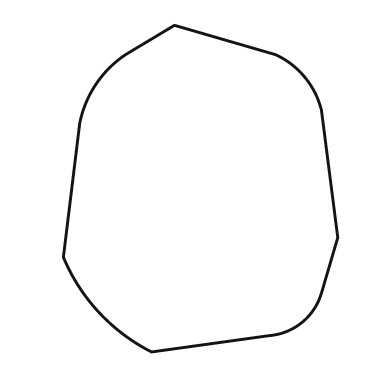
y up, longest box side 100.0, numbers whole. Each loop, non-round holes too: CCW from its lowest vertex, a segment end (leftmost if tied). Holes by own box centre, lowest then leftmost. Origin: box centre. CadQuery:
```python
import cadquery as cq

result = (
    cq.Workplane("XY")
    .moveTo(-15.0, -50.0)
    .lineTo(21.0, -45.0)
    .threePointArc((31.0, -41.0), (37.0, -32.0))
    .lineTo(42.0, -15.0)
    .lineTo(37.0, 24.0)
    .threePointArc((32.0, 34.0), (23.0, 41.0))
    .lineTo(-8.0, 50.0)
    .lineTo(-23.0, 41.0)
    .threePointArc((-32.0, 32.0), (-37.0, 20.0))
    .lineTo(-42.0, -21.0)
    .threePointArc((-31.0, -38.0), (-15.0, -50.0))
    .close()
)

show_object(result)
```